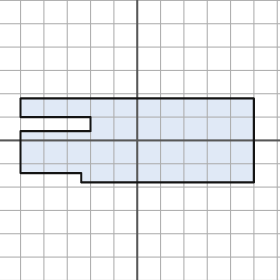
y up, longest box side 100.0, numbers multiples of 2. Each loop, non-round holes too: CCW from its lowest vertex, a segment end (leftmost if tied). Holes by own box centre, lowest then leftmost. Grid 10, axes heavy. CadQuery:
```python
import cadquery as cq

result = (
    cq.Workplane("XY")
    .moveTo(-24.0, -18.0)
    .lineTo(50.0, -18.0)
    .lineTo(50.0, 18.0)
    .lineTo(-50.0, 18.0)
    .lineTo(-50.0, 10.0)
    .lineTo(-20.0, 10.0)
    .lineTo(-20.0, 4.0)
    .lineTo(-50.0, 4.0)
    .lineTo(-50.0, -14.0)
    .lineTo(-24.0, -14.0)
    .close()
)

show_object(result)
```